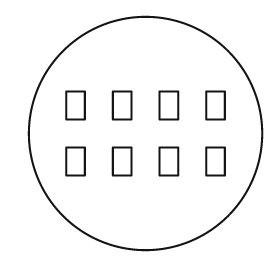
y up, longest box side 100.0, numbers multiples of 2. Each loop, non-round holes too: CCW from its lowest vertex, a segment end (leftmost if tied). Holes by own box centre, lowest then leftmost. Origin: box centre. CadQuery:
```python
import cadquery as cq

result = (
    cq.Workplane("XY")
    .moveTo(0.0, 0.0)
    .circle(50.0)
    .moveTo(-34.0, -18.0)
    .lineTo(-26.0, -18.0)
    .lineTo(-26.0, -6.0)
    .lineTo(-34.0, -6.0)
    .close()
    .moveTo(-14.0, -18.0)
    .lineTo(-6.0, -18.0)
    .lineTo(-6.0, -6.0)
    .lineTo(-14.0, -6.0)
    .close()
    .moveTo(6.0, -18.0)
    .lineTo(14.0, -18.0)
    .lineTo(14.0, -6.0)
    .lineTo(6.0, -6.0)
    .close()
    .moveTo(26.0, -18.0)
    .lineTo(34.0, -18.0)
    .lineTo(34.0, -6.0)
    .lineTo(26.0, -6.0)
    .close()
    .moveTo(-34.0, 6.0)
    .lineTo(-26.0, 6.0)
    .lineTo(-26.0, 18.0)
    .lineTo(-34.0, 18.0)
    .close()
    .moveTo(-14.0, 6.0)
    .lineTo(-6.0, 6.0)
    .lineTo(-6.0, 18.0)
    .lineTo(-14.0, 18.0)
    .close()
    .moveTo(6.0, 6.0)
    .lineTo(14.0, 6.0)
    .lineTo(14.0, 18.0)
    .lineTo(6.0, 18.0)
    .close()
    .moveTo(26.0, 6.0)
    .lineTo(34.0, 6.0)
    .lineTo(34.0, 18.0)
    .lineTo(26.0, 18.0)
    .close()
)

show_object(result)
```